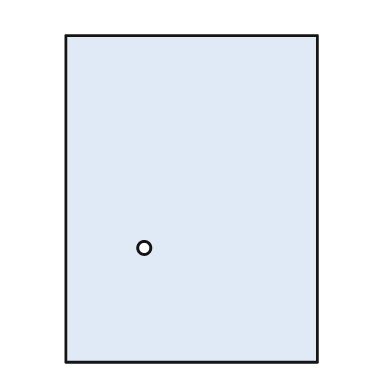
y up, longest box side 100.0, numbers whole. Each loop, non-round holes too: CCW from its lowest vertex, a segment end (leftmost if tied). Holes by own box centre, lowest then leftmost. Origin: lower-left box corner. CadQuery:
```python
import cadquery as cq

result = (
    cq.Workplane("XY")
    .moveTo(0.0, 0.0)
    .lineTo(77.0, 0.0)
    .lineTo(77.0, 100.0)
    .lineTo(0.0, 100.0)
    .close()
    .moveTo(24.0, 35.0)
    .circle(2.0)
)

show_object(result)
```